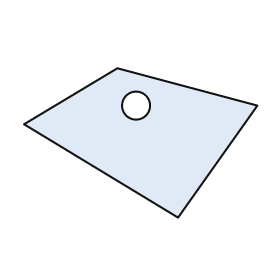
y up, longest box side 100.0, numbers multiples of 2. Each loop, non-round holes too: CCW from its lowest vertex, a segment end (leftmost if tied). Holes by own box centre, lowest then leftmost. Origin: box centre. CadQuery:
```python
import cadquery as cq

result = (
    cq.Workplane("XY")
    .moveTo(16.0, -32.0)
    .lineTo(50.0, 16.0)
    .lineTo(-10.0, 32.0)
    .lineTo(-50.0, 8.0)
    .close()
    .moveTo(-2.0, 16.0)
    .circle(6.0)
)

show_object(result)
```